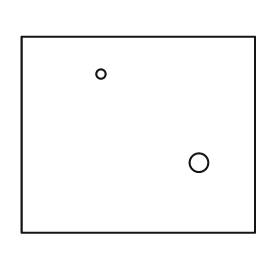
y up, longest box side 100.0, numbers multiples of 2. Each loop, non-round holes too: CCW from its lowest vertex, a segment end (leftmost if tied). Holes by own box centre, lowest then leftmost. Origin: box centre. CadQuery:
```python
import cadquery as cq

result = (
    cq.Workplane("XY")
    .moveTo(-50.0, -42.0)
    .lineTo(50.0, -42.0)
    .lineTo(50.0, 42.0)
    .lineTo(-50.0, 42.0)
    .close()
    .moveTo(26.0, -12.0)
    .circle(4.0)
    .moveTo(-16.0, 26.0)
    .circle(2.0)
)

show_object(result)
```